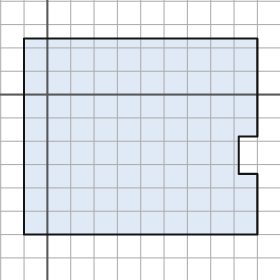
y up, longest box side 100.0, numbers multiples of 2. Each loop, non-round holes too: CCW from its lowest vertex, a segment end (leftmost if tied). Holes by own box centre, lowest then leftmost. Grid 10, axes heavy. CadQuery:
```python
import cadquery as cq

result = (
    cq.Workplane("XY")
    .moveTo(-10.0, -60.0)
    .lineTo(90.0, -60.0)
    .lineTo(90.0, -34.0)
    .lineTo(82.0, -34.0)
    .lineTo(82.0, -18.0)
    .lineTo(90.0, -18.0)
    .lineTo(90.0, 24.0)
    .lineTo(-10.0, 24.0)
    .close()
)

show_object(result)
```